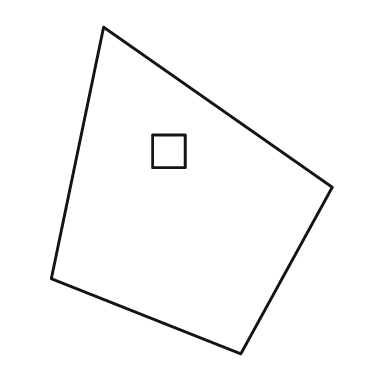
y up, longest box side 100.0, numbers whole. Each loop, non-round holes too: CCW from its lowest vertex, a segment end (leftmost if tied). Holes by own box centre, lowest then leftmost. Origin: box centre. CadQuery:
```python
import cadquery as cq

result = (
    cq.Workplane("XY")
    .moveTo(15.0, -50.0)
    .lineTo(43.0, 1.0)
    .lineTo(-27.0, 50.0)
    .lineTo(-43.0, -27.0)
    .close()
    .moveTo(-12.0, 7.0)
    .lineTo(-2.0, 7.0)
    .lineTo(-2.0, 17.0)
    .lineTo(-12.0, 17.0)
    .close()
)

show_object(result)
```